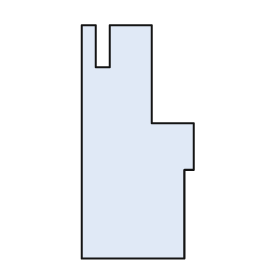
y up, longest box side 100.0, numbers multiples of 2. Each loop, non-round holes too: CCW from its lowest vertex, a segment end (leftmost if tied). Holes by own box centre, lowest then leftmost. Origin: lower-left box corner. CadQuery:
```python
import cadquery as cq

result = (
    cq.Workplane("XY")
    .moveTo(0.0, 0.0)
    .lineTo(44.0, 0.0)
    .lineTo(44.0, 38.0)
    .lineTo(48.0, 38.0)
    .lineTo(48.0, 58.0)
    .lineTo(30.0, 58.0)
    .lineTo(30.0, 100.0)
    .lineTo(12.0, 100.0)
    .lineTo(12.0, 82.0)
    .lineTo(6.0, 82.0)
    .lineTo(6.0, 100.0)
    .lineTo(0.0, 100.0)
    .close()
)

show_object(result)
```